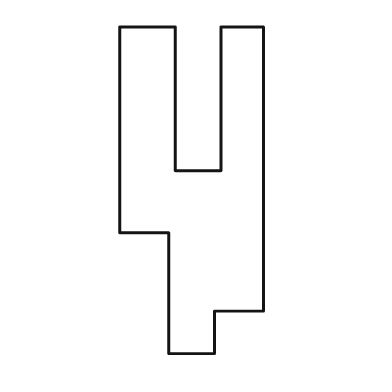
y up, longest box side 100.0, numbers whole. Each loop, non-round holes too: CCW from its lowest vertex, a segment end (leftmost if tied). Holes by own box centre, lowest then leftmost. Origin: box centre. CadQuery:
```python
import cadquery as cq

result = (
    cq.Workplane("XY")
    .moveTo(-7.0, -50.0)
    .lineTo(7.0, -50.0)
    .lineTo(7.0, -37.0)
    .lineTo(22.0, -37.0)
    .lineTo(22.0, 50.0)
    .lineTo(9.0, 50.0)
    .lineTo(9.0, 6.0)
    .lineTo(-5.0, 6.0)
    .lineTo(-5.0, 50.0)
    .lineTo(-22.0, 50.0)
    .lineTo(-22.0, -13.0)
    .lineTo(-7.0, -13.0)
    .close()
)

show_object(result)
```